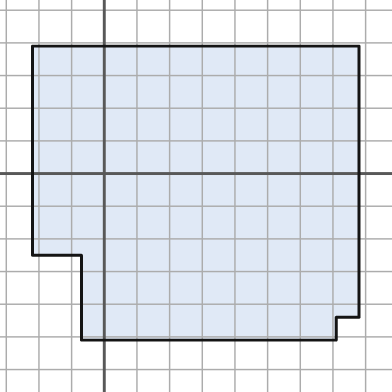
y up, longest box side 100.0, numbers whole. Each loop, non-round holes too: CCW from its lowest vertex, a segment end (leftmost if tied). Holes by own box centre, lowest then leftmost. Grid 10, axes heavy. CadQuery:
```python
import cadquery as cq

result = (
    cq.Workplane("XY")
    .moveTo(-7.0, -51.0)
    .lineTo(71.0, -51.0)
    .lineTo(71.0, -44.0)
    .lineTo(78.0, -44.0)
    .lineTo(78.0, 39.0)
    .lineTo(-22.0, 39.0)
    .lineTo(-22.0, -25.0)
    .lineTo(-7.0, -25.0)
    .close()
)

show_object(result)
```